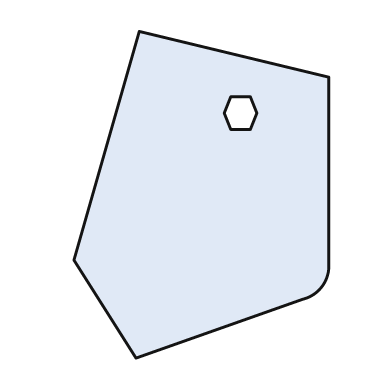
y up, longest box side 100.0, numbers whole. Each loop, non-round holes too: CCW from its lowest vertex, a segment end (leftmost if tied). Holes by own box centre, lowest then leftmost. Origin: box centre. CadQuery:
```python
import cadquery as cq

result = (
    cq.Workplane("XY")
    .moveTo(-20.0, -50.0)
    .lineTo(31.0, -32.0)
    .threePointArc((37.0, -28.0), (39.0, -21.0))
    .lineTo(39.0, 36.0)
    .lineTo(-19.0, 50.0)
    .lineTo(-39.0, -20.0)
    .close()
    .moveTo(9.0, 20.0)
    .lineTo(15.0, 20.0)
    .lineTo(17.0, 25.0)
    .lineTo(15.0, 30.0)
    .lineTo(9.0, 30.0)
    .lineTo(7.0, 25.0)
    .close()
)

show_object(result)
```